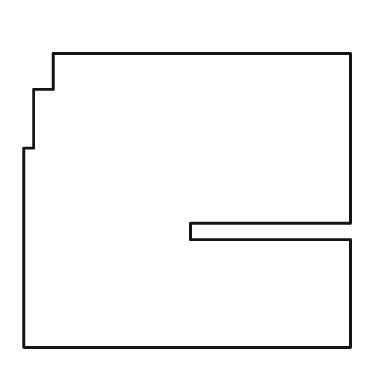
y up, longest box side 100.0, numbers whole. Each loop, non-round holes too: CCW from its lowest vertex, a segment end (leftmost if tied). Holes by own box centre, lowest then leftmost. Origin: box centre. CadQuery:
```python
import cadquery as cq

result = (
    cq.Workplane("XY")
    .moveTo(-50.0, -45.0)
    .lineTo(50.0, -45.0)
    .lineTo(50.0, -12.0)
    .lineTo(1.0, -12.0)
    .lineTo(1.0, -7.0)
    .lineTo(50.0, -7.0)
    .lineTo(50.0, 45.0)
    .lineTo(-41.0, 45.0)
    .lineTo(-41.0, 34.0)
    .lineTo(-47.0, 34.0)
    .lineTo(-47.0, 16.0)
    .lineTo(-50.0, 16.0)
    .close()
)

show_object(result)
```